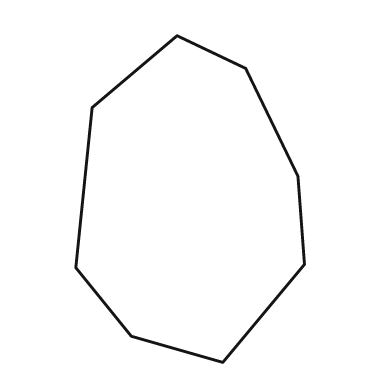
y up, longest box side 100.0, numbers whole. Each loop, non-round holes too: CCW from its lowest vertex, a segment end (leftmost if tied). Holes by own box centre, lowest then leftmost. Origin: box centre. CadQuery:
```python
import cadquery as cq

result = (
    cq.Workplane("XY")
    .moveTo(10.0, -50.0)
    .lineTo(35.0, -20.0)
    .lineTo(33.0, 7.0)
    .lineTo(17.0, 40.0)
    .lineTo(-4.0, 50.0)
    .lineTo(-30.0, 28.0)
    .lineTo(-35.0, -21.0)
    .lineTo(-18.0, -42.0)
    .close()
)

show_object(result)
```